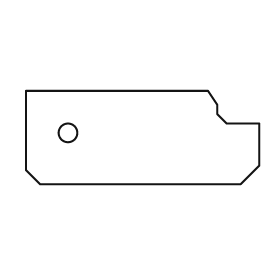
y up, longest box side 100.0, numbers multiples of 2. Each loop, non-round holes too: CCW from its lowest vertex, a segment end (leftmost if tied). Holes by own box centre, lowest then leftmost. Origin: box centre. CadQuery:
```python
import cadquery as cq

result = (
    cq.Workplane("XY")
    .moveTo(-44.0, -20.0)
    .lineTo(42.0, -20.0)
    .lineTo(50.0, -12.0)
    .lineTo(50.0, 6.0)
    .lineTo(36.0, 6.0)
    .lineTo(32.0, 10.0)
    .lineTo(32.0, 14.0)
    .lineTo(28.0, 20.0)
    .lineTo(-50.0, 20.0)
    .lineTo(-50.0, -14.0)
    .close()
    .moveTo(-32.0, 2.0)
    .circle(4.0)
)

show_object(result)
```